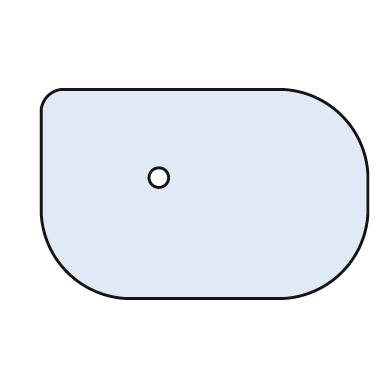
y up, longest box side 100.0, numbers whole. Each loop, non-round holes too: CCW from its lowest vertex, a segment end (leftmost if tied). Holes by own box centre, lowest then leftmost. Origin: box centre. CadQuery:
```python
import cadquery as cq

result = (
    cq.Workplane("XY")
    .moveTo(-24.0, -32.0)
    .lineTo(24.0, -32.0)
    .threePointArc((42.0, -24.0), (50.0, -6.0))
    .lineTo(50.0, 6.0)
    .threePointArc((42.0, 24.0), (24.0, 32.0))
    .lineTo(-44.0, 32.0)
    .threePointArc((-48.0, 30.0), (-50.0, 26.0))
    .lineTo(-50.0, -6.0)
    .threePointArc((-42.0, -24.0), (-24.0, -32.0))
    .close()
    .moveTo(-14.0, 5.0)
    .circle(3.0)
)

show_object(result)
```